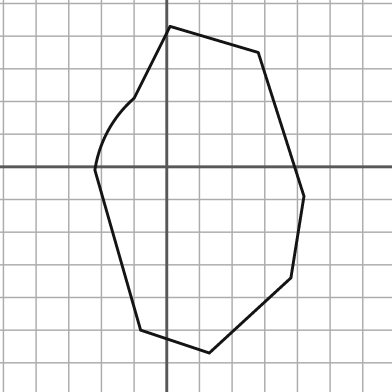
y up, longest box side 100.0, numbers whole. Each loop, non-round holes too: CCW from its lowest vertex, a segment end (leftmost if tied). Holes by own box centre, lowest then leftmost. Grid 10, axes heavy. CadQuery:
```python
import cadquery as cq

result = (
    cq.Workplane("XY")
    .moveTo(13.0, -57.0)
    .lineTo(38.0, -34.0)
    .lineTo(42.0, -9.0)
    .lineTo(28.0, 35.0)
    .lineTo(1.0, 43.0)
    .lineTo(-10.0, 21.0)
    .threePointArc((-18.0, 11.0), (-22.0, -1.0))
    .lineTo(-8.0, -50.0)
    .close()
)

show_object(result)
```